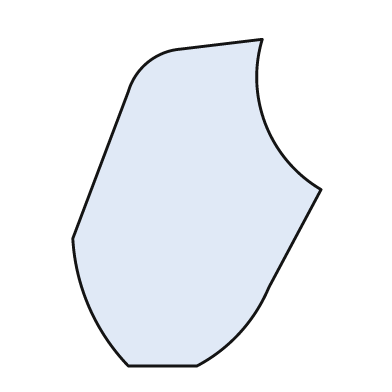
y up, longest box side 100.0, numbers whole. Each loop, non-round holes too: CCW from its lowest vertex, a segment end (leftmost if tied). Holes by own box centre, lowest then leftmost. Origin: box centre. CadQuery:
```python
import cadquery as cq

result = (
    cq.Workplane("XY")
    .moveTo(-21.0, -50.0)
    .lineTo(0.0, -50.0)
    .threePointArc((13.0, -40.0), (22.0, -26.0))
    .lineTo(38.0, 4.0)
    .threePointArc((21.0, 24.0), (20.0, 50.0))
    .lineTo(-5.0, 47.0)
    .threePointArc((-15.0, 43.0), (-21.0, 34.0))
    .lineTo(-38.0, -11.0)
    .threePointArc((-33.0, -32.0), (-21.0, -50.0))
    .close()
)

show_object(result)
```